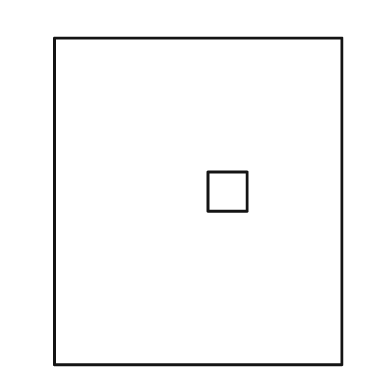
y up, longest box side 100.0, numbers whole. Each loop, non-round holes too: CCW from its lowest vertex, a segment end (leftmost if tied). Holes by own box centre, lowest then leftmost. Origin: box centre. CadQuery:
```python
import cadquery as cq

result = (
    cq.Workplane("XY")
    .moveTo(-44.0, -50.0)
    .lineTo(44.0, -50.0)
    .lineTo(44.0, 50.0)
    .lineTo(-44.0, 50.0)
    .close()
    .moveTo(3.0, -3.0)
    .lineTo(15.0, -3.0)
    .lineTo(15.0, 9.0)
    .lineTo(3.0, 9.0)
    .close()
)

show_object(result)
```